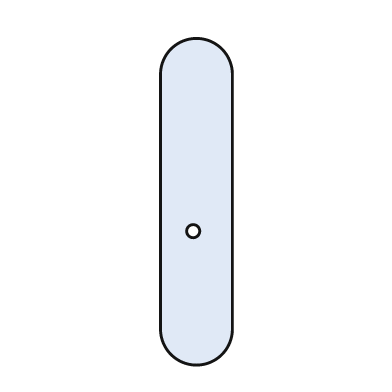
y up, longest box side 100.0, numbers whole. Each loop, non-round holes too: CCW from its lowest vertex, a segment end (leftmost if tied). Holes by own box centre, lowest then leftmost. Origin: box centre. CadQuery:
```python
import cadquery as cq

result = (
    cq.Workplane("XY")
    .moveTo(-11.0, -39.0)
    .threePointArc((0.0, -50.0), (11.0, -39.0))
    .lineTo(11.0, 39.0)
    .threePointArc((0.0, 50.0), (-11.0, 39.0))
    .close()
    .moveTo(-1.0, -9.0)
    .circle(2.0)
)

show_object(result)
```